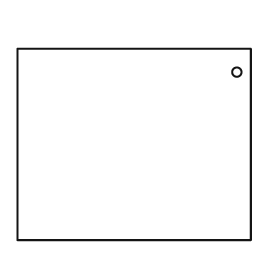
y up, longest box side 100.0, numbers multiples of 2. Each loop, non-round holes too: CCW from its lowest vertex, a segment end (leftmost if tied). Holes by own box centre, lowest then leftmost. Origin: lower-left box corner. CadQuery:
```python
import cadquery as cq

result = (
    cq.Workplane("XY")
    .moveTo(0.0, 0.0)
    .lineTo(100.0, 0.0)
    .lineTo(100.0, 82.0)
    .lineTo(0.0, 82.0)
    .close()
    .moveTo(94.0, 72.0)
    .circle(2.0)
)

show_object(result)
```